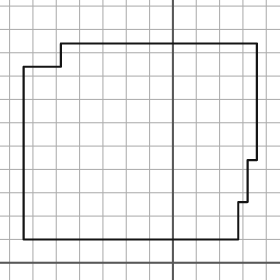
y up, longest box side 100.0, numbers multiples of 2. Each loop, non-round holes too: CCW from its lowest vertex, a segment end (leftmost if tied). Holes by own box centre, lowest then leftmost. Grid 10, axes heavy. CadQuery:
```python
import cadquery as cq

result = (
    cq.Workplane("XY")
    .moveTo(-64.0, 10.0)
    .lineTo(28.0, 10.0)
    .lineTo(28.0, 26.0)
    .lineTo(32.0, 26.0)
    .lineTo(32.0, 44.0)
    .lineTo(36.0, 44.0)
    .lineTo(36.0, 94.0)
    .lineTo(-48.0, 94.0)
    .lineTo(-48.0, 84.0)
    .lineTo(-64.0, 84.0)
    .close()
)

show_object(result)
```